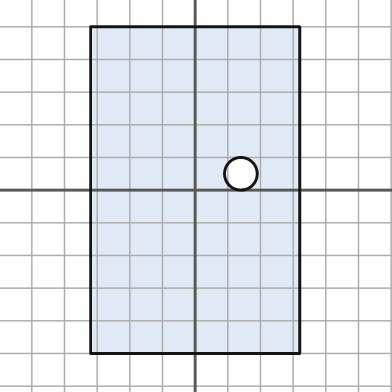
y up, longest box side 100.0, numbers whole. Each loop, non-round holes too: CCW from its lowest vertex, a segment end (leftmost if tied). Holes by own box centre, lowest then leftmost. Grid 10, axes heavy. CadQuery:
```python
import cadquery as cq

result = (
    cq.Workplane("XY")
    .moveTo(-32.0, -50.0)
    .lineTo(32.0, -50.0)
    .lineTo(32.0, 50.0)
    .lineTo(-32.0, 50.0)
    .close()
    .moveTo(14.0, 5.0)
    .circle(5.0)
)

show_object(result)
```